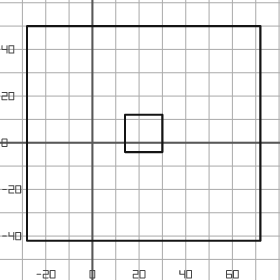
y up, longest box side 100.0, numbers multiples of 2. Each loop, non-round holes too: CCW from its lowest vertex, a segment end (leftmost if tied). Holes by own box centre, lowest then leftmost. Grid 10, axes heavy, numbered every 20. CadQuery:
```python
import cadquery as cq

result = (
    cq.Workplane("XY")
    .moveTo(-28.0, -42.0)
    .lineTo(72.0, -42.0)
    .lineTo(72.0, 50.0)
    .lineTo(-28.0, 50.0)
    .close()
    .moveTo(14.0, -4.0)
    .lineTo(30.0, -4.0)
    .lineTo(30.0, 12.0)
    .lineTo(14.0, 12.0)
    .close()
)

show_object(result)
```